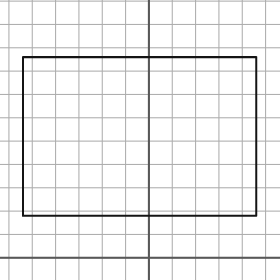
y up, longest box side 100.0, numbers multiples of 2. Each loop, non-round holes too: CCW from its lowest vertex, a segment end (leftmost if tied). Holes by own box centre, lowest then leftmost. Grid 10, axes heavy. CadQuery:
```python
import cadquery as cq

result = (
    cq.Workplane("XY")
    .moveTo(-54.0, 18.0)
    .lineTo(46.0, 18.0)
    .lineTo(46.0, 86.0)
    .lineTo(-54.0, 86.0)
    .close()
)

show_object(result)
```